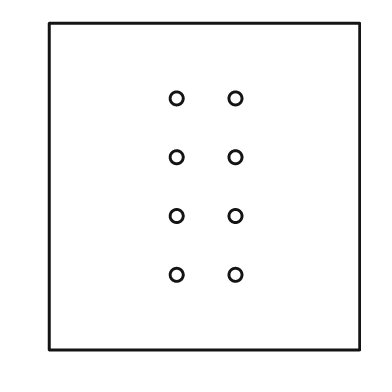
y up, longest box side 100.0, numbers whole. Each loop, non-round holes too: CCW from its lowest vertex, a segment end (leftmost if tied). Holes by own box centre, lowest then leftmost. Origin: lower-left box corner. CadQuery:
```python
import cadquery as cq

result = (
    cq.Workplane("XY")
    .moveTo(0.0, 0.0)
    .lineTo(95.0, 0.0)
    .lineTo(95.0, 100.0)
    .lineTo(0.0, 100.0)
    .close()
    .moveTo(39.0, 23.0)
    .circle(2.0)
    .moveTo(57.0, 23.0)
    .circle(2.0)
    .moveTo(39.0, 41.0)
    .circle(2.0)
    .moveTo(57.0, 41.0)
    .circle(2.0)
    .moveTo(39.0, 59.0)
    .circle(2.0)
    .moveTo(57.0, 59.0)
    .circle(2.0)
    .moveTo(39.0, 77.0)
    .circle(2.0)
    .moveTo(57.0, 77.0)
    .circle(2.0)
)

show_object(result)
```